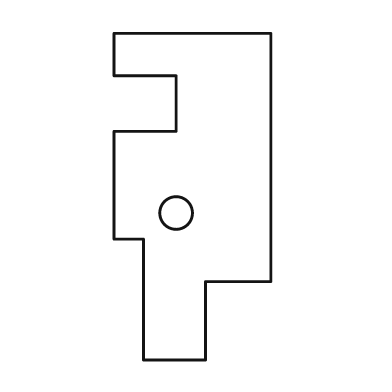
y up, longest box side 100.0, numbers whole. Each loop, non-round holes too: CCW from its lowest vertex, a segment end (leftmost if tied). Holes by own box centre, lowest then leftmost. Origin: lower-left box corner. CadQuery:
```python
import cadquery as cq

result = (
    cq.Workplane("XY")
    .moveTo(9.0, 0.0)
    .lineTo(28.0, 0.0)
    .lineTo(28.0, 24.0)
    .lineTo(48.0, 24.0)
    .lineTo(48.0, 100.0)
    .lineTo(0.0, 100.0)
    .lineTo(0.0, 87.0)
    .lineTo(19.0, 87.0)
    .lineTo(19.0, 70.0)
    .lineTo(0.0, 70.0)
    .lineTo(0.0, 37.0)
    .lineTo(9.0, 37.0)
    .close()
    .moveTo(19.0, 45.0)
    .circle(5.0)
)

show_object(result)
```